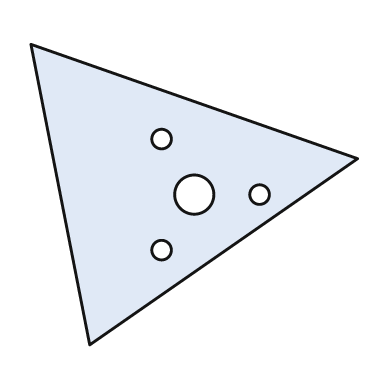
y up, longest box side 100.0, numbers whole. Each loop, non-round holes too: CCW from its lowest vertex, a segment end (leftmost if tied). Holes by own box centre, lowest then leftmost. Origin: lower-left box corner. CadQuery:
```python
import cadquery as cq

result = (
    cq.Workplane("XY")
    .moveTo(18.0, 0.0)
    .lineTo(100.0, 57.0)
    .lineTo(0.0, 92.0)
    .close()
    .moveTo(40.0, 29.0)
    .circle(3.0)
    .moveTo(50.0, 46.0)
    .circle(6.0)
    .moveTo(70.0, 46.0)
    .circle(3.0)
    .moveTo(40.0, 63.0)
    .circle(3.0)
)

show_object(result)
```